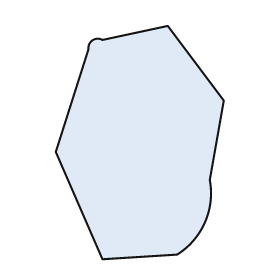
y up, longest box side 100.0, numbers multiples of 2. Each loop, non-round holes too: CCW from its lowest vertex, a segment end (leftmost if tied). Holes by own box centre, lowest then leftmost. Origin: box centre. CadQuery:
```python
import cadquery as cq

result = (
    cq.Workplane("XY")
    .moveTo(-16.0, -50.0)
    .lineTo(16.0, -48.0)
    .threePointArc((28.0, -34.0), (30.0, -16.0))
    .lineTo(36.0, 18.0)
    .lineTo(12.0, 50.0)
    .lineTo(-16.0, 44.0)
    .threePointArc((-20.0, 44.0), (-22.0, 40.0))
    .lineTo(-36.0, -4.0)
    .close()
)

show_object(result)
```